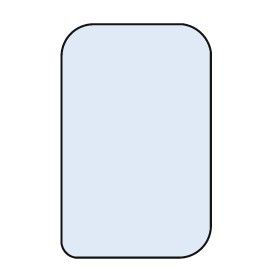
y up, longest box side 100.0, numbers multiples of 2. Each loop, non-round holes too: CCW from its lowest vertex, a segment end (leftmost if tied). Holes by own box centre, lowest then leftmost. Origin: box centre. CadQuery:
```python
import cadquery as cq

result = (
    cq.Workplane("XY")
    .moveTo(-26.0, -50.0)
    .lineTo(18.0, -50.0)
    .threePointArc((28.0, -46.0), (32.0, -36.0))
    .lineTo(32.0, 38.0)
    .threePointArc((28.0, 46.0), (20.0, 50.0))
    .lineTo(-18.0, 50.0)
    .threePointArc((-28.0, 46.0), (-32.0, 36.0))
    .lineTo(-32.0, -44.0)
    .threePointArc((-30.0, -48.0), (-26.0, -50.0))
    .close()
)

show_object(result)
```